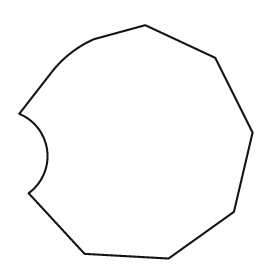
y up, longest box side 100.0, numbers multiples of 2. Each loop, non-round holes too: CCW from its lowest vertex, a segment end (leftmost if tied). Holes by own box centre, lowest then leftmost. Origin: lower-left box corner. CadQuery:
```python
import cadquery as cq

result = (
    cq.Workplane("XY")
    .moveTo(64.0, 0.0)
    .lineTo(92.0, 20.0)
    .lineTo(100.0, 54.0)
    .lineTo(84.0, 86.0)
    .lineTo(54.0, 100.0)
    .lineTo(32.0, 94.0)
    .threePointArc((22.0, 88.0), (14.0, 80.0))
    .lineTo(0.0, 62.0)
    .threePointArc((12.0, 46.0), (4.0, 28.0))
    .lineTo(28.0, 2.0)
    .close()
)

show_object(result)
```